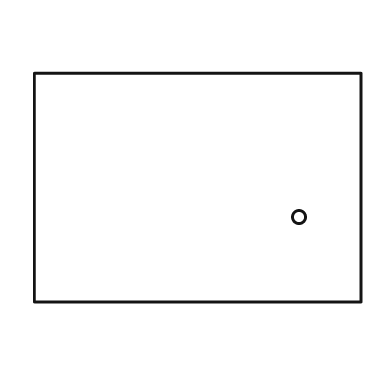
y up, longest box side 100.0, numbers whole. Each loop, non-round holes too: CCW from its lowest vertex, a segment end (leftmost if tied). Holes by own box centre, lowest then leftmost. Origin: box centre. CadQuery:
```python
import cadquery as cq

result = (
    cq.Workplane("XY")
    .moveTo(-50.0, -35.0)
    .lineTo(50.0, -35.0)
    .lineTo(50.0, 35.0)
    .lineTo(-50.0, 35.0)
    .close()
    .moveTo(31.0, -9.0)
    .circle(2.0)
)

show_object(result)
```